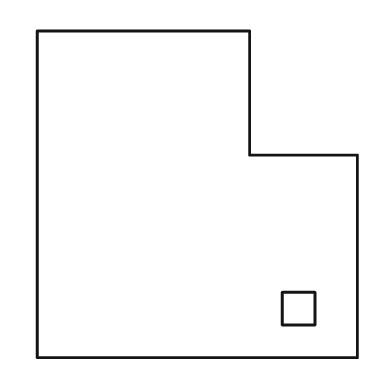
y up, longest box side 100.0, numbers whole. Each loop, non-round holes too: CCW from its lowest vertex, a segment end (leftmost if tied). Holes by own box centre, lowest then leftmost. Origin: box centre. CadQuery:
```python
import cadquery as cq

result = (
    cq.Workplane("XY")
    .moveTo(-49.0, -50.0)
    .lineTo(49.0, -50.0)
    .lineTo(49.0, 12.0)
    .lineTo(16.0, 12.0)
    .lineTo(16.0, 50.0)
    .lineTo(-49.0, 50.0)
    .close()
    .moveTo(26.0, -40.0)
    .lineTo(36.0, -40.0)
    .lineTo(36.0, -30.0)
    .lineTo(26.0, -30.0)
    .close()
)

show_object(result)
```